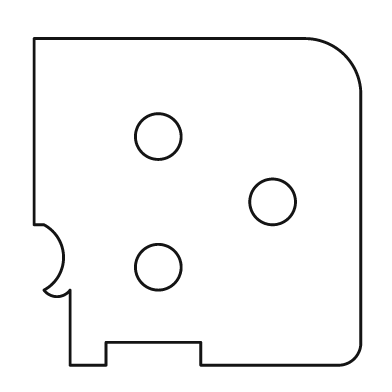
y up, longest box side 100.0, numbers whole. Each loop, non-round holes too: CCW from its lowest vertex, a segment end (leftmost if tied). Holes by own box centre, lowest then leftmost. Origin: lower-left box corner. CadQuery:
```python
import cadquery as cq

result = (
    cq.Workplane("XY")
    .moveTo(11.0, 0.0)
    .lineTo(22.0, 0.0)
    .lineTo(22.0, 7.0)
    .lineTo(51.0, 7.0)
    .lineTo(51.0, 0.0)
    .lineTo(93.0, 0.0)
    .threePointArc((98.0, 2.0), (100.0, 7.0))
    .lineTo(100.0, 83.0)
    .threePointArc((95.0, 95.0), (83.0, 100.0))
    .lineTo(0.0, 100.0)
    .lineTo(0.0, 43.0)
    .lineTo(3.0, 43.0)
    .threePointArc((9.0, 33.0), (3.0, 23.0))
    .threePointArc((7.0, 21.0), (11.0, 23.0))
    .close()
    .moveTo(38.0, 30.0)
    .circle(7.0)
    .moveTo(73.0, 50.0)
    .circle(7.0)
    .moveTo(38.0, 70.0)
    .circle(7.0)
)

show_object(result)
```